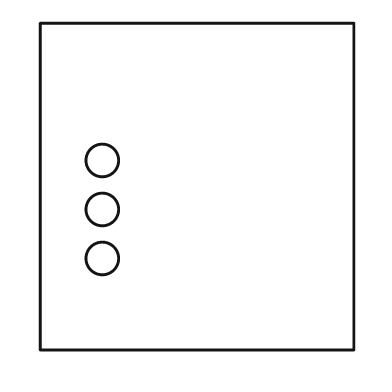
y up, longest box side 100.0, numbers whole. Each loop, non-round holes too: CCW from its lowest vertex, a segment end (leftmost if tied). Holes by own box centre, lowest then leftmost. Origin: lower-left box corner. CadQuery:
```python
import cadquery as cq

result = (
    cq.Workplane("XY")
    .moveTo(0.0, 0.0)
    .lineTo(96.0, 0.0)
    .lineTo(96.0, 100.0)
    .lineTo(0.0, 100.0)
    .close()
    .moveTo(19.0, 28.0)
    .circle(5.0)
    .moveTo(19.0, 43.0)
    .circle(5.0)
    .moveTo(19.0, 58.0)
    .circle(5.0)
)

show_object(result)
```